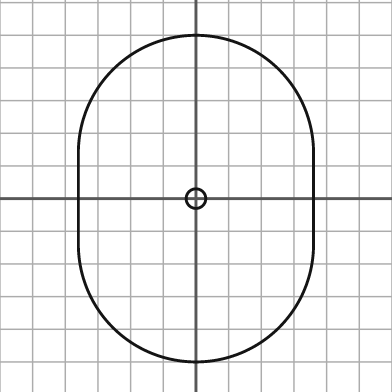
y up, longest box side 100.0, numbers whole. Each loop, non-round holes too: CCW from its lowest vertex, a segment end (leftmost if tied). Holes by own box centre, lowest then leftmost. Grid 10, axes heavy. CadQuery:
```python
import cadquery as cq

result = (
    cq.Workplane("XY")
    .moveTo(-36.0, -14.0)
    .threePointArc((0.0, -50.0), (36.0, -14.0))
    .lineTo(36.0, 14.0)
    .threePointArc((0.0, 50.0), (-36.0, 14.0))
    .close()
    .moveTo(0.0, 0.0)
    .circle(3.0)
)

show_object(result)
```